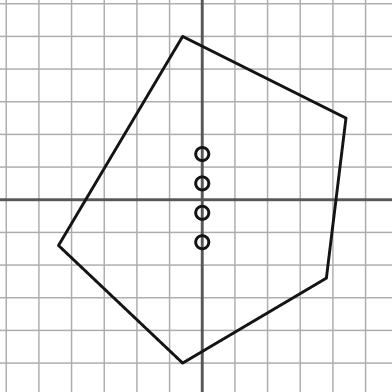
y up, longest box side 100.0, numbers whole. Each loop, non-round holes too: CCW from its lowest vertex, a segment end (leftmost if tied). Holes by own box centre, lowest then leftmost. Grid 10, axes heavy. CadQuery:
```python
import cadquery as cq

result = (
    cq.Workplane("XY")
    .moveTo(-6.0, -50.0)
    .lineTo(38.0, -24.0)
    .lineTo(44.0, 25.0)
    .lineTo(-6.0, 50.0)
    .lineTo(-44.0, -14.0)
    .close()
    .moveTo(0.0, -13.0)
    .circle(2.0)
    .moveTo(0.0, -4.0)
    .circle(2.0)
    .moveTo(0.0, 5.0)
    .circle(2.0)
    .moveTo(0.0, 14.0)
    .circle(2.0)
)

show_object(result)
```